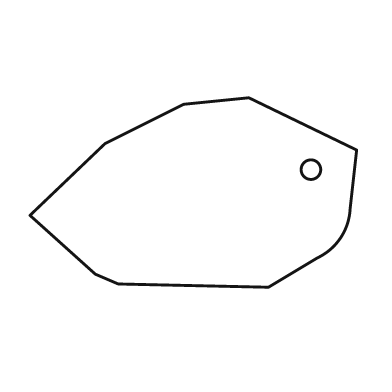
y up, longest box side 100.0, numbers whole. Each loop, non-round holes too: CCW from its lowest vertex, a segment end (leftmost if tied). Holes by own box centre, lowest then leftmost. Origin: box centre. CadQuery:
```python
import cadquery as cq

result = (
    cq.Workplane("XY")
    .moveTo(23.0, -29.0)
    .lineTo(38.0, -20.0)
    .threePointArc((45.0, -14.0), (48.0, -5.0))
    .lineTo(50.0, 13.0)
    .lineTo(17.0, 29.0)
    .lineTo(-3.0, 27.0)
    .lineTo(-27.0, 15.0)
    .lineTo(-50.0, -7.0)
    .lineTo(-30.0, -25.0)
    .lineTo(-23.0, -28.0)
    .close()
    .moveTo(36.0, 7.0)
    .circle(3.0)
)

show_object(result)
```